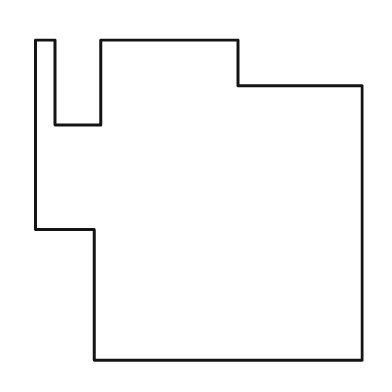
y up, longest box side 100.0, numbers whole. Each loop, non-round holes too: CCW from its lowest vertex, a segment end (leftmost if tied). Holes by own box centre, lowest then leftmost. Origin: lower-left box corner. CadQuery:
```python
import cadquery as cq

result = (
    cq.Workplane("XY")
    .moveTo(18.0, 0.0)
    .lineTo(100.0, 0.0)
    .lineTo(100.0, 84.0)
    .lineTo(62.0, 84.0)
    .lineTo(62.0, 98.0)
    .lineTo(20.0, 98.0)
    .lineTo(20.0, 72.0)
    .lineTo(6.0, 72.0)
    .lineTo(6.0, 98.0)
    .lineTo(0.0, 98.0)
    .lineTo(0.0, 40.0)
    .lineTo(18.0, 40.0)
    .close()
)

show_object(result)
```